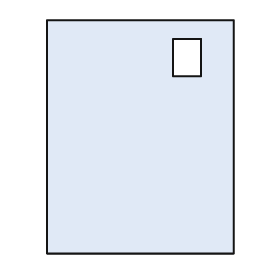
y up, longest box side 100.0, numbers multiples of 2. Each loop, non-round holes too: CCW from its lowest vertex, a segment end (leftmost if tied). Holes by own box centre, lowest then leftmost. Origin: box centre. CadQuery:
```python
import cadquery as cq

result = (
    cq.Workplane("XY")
    .moveTo(-40.0, -50.0)
    .lineTo(40.0, -50.0)
    .lineTo(40.0, 50.0)
    .lineTo(-40.0, 50.0)
    .close()
    .moveTo(14.0, 26.0)
    .lineTo(26.0, 26.0)
    .lineTo(26.0, 42.0)
    .lineTo(14.0, 42.0)
    .close()
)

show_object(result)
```